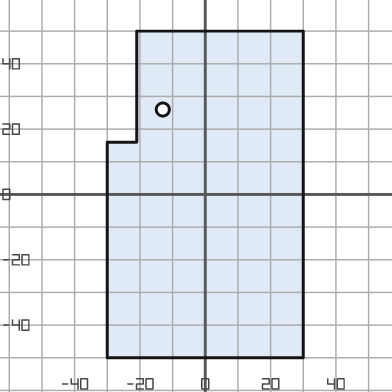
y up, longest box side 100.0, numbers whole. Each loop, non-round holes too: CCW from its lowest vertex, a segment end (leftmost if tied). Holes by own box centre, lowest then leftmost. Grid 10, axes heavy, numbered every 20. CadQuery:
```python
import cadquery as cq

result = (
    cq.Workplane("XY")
    .moveTo(-30.0, -50.0)
    .lineTo(30.0, -50.0)
    .lineTo(30.0, 50.0)
    .lineTo(-21.0, 50.0)
    .lineTo(-21.0, 16.0)
    .lineTo(-30.0, 16.0)
    .close()
    .moveTo(-13.0, 26.0)
    .circle(2.0)
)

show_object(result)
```